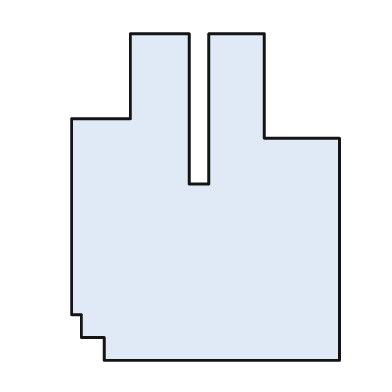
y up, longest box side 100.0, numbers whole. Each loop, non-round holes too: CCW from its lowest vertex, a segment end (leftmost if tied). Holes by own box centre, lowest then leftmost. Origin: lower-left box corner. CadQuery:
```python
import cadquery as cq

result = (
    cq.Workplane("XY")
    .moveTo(10.0, 0.0)
    .lineTo(82.0, 0.0)
    .lineTo(82.0, 68.0)
    .lineTo(59.0, 68.0)
    .lineTo(59.0, 100.0)
    .lineTo(42.0, 100.0)
    .lineTo(42.0, 54.0)
    .lineTo(36.0, 54.0)
    .lineTo(36.0, 100.0)
    .lineTo(18.0, 100.0)
    .lineTo(18.0, 74.0)
    .lineTo(0.0, 74.0)
    .lineTo(0.0, 14.0)
    .lineTo(3.0, 14.0)
    .lineTo(3.0, 7.0)
    .lineTo(10.0, 7.0)
    .close()
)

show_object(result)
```